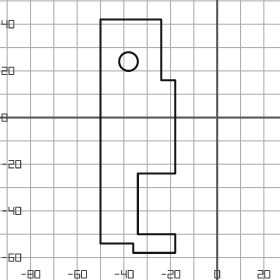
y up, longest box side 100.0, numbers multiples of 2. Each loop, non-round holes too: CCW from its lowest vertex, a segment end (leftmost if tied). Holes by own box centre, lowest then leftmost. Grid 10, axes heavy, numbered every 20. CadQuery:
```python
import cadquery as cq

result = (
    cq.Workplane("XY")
    .moveTo(-36.0, -58.0)
    .lineTo(-18.0, -58.0)
    .lineTo(-18.0, -50.0)
    .lineTo(-34.0, -50.0)
    .lineTo(-34.0, -24.0)
    .lineTo(-18.0, -24.0)
    .lineTo(-18.0, 16.0)
    .lineTo(-24.0, 16.0)
    .lineTo(-24.0, 42.0)
    .lineTo(-50.0, 42.0)
    .lineTo(-50.0, -54.0)
    .lineTo(-36.0, -54.0)
    .close()
    .moveTo(-38.0, 24.0)
    .circle(4.0)
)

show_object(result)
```